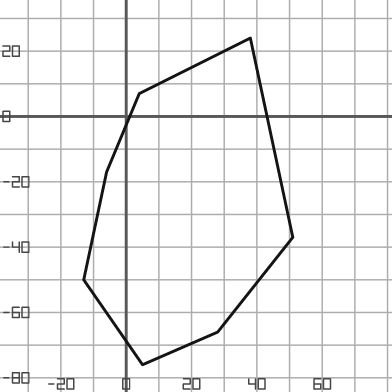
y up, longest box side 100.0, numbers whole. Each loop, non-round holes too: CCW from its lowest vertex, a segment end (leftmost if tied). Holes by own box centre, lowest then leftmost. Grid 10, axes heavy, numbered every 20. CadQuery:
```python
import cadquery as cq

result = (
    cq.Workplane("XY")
    .moveTo(5.0, -76.0)
    .lineTo(28.0, -66.0)
    .lineTo(51.0, -37.0)
    .lineTo(38.0, 24.0)
    .lineTo(4.0, 7.0)
    .lineTo(-6.0, -17.0)
    .lineTo(-13.0, -50.0)
    .close()
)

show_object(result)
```